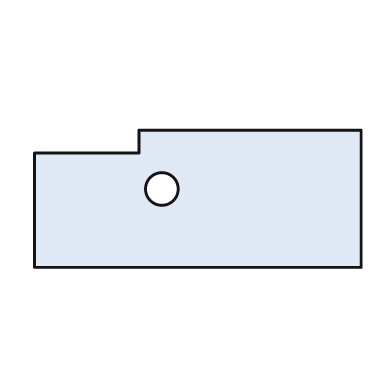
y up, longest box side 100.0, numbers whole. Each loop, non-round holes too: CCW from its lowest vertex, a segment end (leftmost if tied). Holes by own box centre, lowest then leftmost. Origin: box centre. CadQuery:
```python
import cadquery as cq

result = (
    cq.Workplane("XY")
    .moveTo(-50.0, -21.0)
    .lineTo(50.0, -21.0)
    .lineTo(50.0, 21.0)
    .lineTo(-18.0, 21.0)
    .lineTo(-18.0, 14.0)
    .lineTo(-50.0, 14.0)
    .close()
    .moveTo(-11.0, 3.0)
    .circle(5.0)
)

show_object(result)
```